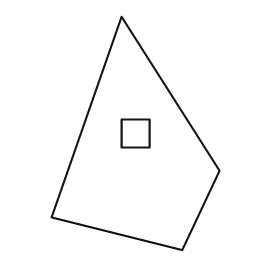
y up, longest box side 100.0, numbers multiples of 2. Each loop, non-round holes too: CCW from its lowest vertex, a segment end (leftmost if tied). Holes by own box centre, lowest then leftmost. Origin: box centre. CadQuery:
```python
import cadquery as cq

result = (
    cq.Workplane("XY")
    .moveTo(20.0, -50.0)
    .lineTo(36.0, -16.0)
    .lineTo(-6.0, 50.0)
    .lineTo(-36.0, -36.0)
    .close()
    .moveTo(-6.0, -6.0)
    .lineTo(6.0, -6.0)
    .lineTo(6.0, 6.0)
    .lineTo(-6.0, 6.0)
    .close()
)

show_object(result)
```